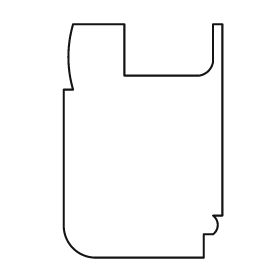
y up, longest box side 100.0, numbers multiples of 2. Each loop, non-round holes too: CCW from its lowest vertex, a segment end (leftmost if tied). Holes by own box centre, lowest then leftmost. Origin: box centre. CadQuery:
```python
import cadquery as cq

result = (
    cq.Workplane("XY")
    .moveTo(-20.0, -50.0)
    .lineTo(26.0, -50.0)
    .lineTo(26.0, -40.0)
    .lineTo(30.0, -40.0)
    .threePointArc((32.0, -36.0), (30.0, -32.0))
    .lineTo(34.0, -32.0)
    .lineTo(34.0, 50.0)
    .lineTo(30.0, 50.0)
    .lineTo(30.0, 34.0)
    .threePointArc((28.0, 30.0), (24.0, 28.0))
    .lineTo(-8.0, 28.0)
    .lineTo(-8.0, 50.0)
    .lineTo(-30.0, 50.0)
    .threePointArc((-32.0, 36.0), (-30.0, 22.0))
    .lineTo(-34.0, 22.0)
    .lineTo(-34.0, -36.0)
    .threePointArc((-30.0, -46.0), (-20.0, -50.0))
    .close()
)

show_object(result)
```